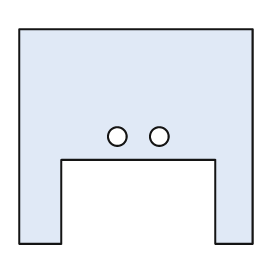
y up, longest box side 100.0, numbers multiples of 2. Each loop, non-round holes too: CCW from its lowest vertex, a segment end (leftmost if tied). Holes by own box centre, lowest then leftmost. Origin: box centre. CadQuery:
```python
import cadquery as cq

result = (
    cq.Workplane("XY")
    .moveTo(-50.0, -46.0)
    .lineTo(-32.0, -46.0)
    .lineTo(-32.0, -10.0)
    .lineTo(34.0, -10.0)
    .lineTo(34.0, -46.0)
    .lineTo(50.0, -46.0)
    .lineTo(50.0, 46.0)
    .lineTo(-50.0, 46.0)
    .close()
    .moveTo(-8.0, 0.0)
    .circle(4.0)
    .moveTo(10.0, 0.0)
    .circle(4.0)
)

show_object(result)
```